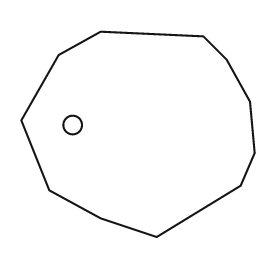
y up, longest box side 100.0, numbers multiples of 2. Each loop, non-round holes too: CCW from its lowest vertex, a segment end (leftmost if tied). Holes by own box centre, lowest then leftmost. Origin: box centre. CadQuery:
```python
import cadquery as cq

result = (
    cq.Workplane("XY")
    .moveTo(8.0, -44.0)
    .lineTo(44.0, -22.0)
    .lineTo(50.0, -8.0)
    .lineTo(48.0, 14.0)
    .lineTo(38.0, 32.0)
    .lineTo(28.0, 42.0)
    .lineTo(-16.0, 44.0)
    .lineTo(-34.0, 34.0)
    .lineTo(-50.0, 6.0)
    .lineTo(-38.0, -24.0)
    .lineTo(-16.0, -36.0)
    .close()
    .moveTo(-28.0, 4.0)
    .circle(4.0)
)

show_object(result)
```